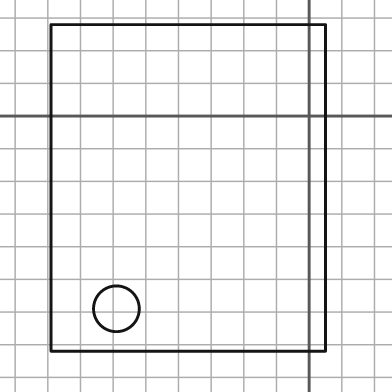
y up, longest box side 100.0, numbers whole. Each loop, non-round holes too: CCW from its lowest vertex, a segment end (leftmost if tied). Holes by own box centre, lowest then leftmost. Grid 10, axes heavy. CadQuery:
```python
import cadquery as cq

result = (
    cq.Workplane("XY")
    .moveTo(-79.0, -72.0)
    .lineTo(5.0, -72.0)
    .lineTo(5.0, 28.0)
    .lineTo(-79.0, 28.0)
    .close()
    .moveTo(-59.0, -59.0)
    .circle(7.0)
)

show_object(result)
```